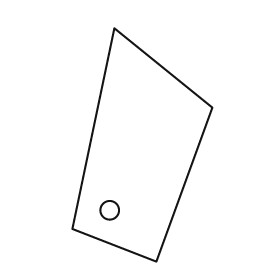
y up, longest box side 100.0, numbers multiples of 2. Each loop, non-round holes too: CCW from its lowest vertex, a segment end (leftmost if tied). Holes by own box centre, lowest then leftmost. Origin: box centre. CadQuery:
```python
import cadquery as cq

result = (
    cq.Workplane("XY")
    .moveTo(6.0, -50.0)
    .lineTo(30.0, 16.0)
    .lineTo(-12.0, 50.0)
    .lineTo(-30.0, -36.0)
    .close()
    .moveTo(-14.0, -28.0)
    .circle(4.0)
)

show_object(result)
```